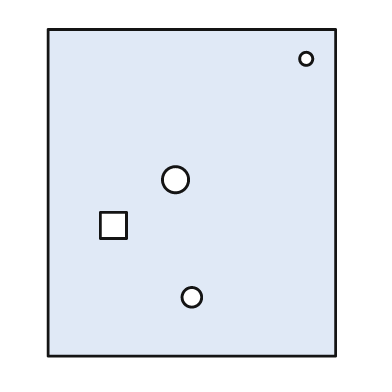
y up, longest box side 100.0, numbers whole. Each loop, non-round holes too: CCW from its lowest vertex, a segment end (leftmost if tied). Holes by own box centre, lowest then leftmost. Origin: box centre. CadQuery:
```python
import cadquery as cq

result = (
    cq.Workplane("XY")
    .moveTo(-44.0, -50.0)
    .lineTo(44.0, -50.0)
    .lineTo(44.0, 50.0)
    .lineTo(-44.0, 50.0)
    .close()
    .moveTo(0.0, -32.0)
    .circle(3.0)
    .moveTo(-28.0, -14.0)
    .lineTo(-20.0, -14.0)
    .lineTo(-20.0, -6.0)
    .lineTo(-28.0, -6.0)
    .close()
    .moveTo(-5.0, 4.0)
    .circle(4.0)
    .moveTo(35.0, 41.0)
    .circle(2.0)
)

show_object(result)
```